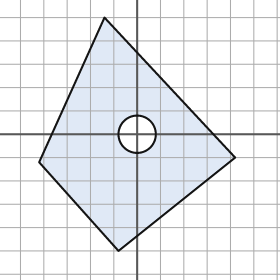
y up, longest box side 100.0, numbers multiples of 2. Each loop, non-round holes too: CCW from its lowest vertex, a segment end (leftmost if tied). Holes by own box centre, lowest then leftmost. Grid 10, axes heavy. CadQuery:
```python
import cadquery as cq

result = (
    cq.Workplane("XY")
    .moveTo(-8.0, -50.0)
    .lineTo(42.0, -10.0)
    .lineTo(-14.0, 50.0)
    .lineTo(-42.0, -12.0)
    .close()
    .moveTo(0.0, 0.0)
    .circle(8.0)
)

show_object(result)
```